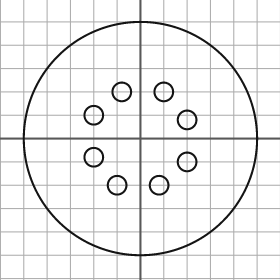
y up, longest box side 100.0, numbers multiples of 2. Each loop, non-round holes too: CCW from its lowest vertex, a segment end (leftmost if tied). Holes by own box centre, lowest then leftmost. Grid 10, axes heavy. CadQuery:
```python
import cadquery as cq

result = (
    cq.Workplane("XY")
    .moveTo(0.0, 0.0)
    .circle(50.0)
    .moveTo(-10.0, -20.0)
    .circle(4.0)
    .moveTo(8.0, -20.0)
    .circle(4.0)
    .moveTo(20.0, -10.0)
    .circle(4.0)
    .moveTo(-20.0, -8.0)
    .circle(4.0)
    .moveTo(20.0, 8.0)
    .circle(4.0)
    .moveTo(-20.0, 10.0)
    .circle(4.0)
    .moveTo(-8.0, 20.0)
    .circle(4.0)
    .moveTo(10.0, 20.0)
    .circle(4.0)
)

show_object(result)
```